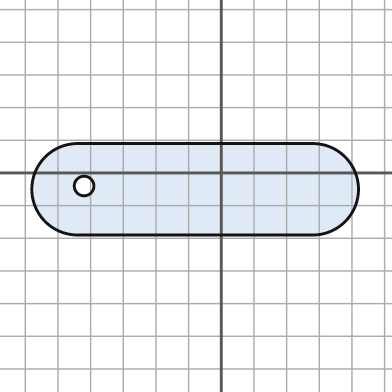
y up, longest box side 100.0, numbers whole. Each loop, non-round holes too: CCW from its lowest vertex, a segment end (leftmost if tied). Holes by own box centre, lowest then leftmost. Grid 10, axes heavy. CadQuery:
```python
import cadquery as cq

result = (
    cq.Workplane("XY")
    .moveTo(-44.0, -19.0)
    .lineTo(28.0, -19.0)
    .threePointArc((42.0, -5.0), (28.0, 9.0))
    .lineTo(-44.0, 9.0)
    .threePointArc((-58.0, -5.0), (-44.0, -19.0))
    .close()
    .moveTo(-42.0, -4.0)
    .circle(3.0)
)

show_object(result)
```